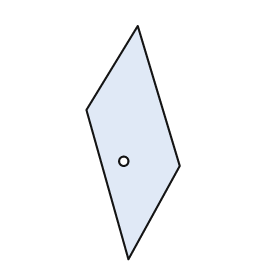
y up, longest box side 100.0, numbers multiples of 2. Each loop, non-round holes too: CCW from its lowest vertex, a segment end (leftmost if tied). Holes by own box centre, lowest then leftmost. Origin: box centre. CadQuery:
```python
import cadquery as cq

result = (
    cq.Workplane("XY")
    .moveTo(-2.0, -50.0)
    .lineTo(20.0, -10.0)
    .lineTo(2.0, 50.0)
    .lineTo(-20.0, 14.0)
    .close()
    .moveTo(-4.0, -8.0)
    .circle(2.0)
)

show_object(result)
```